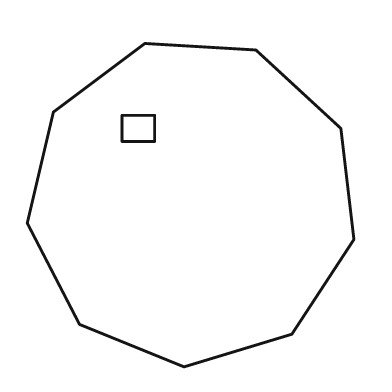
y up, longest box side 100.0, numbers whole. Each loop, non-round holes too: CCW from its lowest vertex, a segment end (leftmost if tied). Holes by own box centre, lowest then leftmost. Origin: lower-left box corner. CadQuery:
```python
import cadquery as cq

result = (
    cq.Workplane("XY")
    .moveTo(48.0, 0.0)
    .lineTo(81.0, 10.0)
    .lineTo(100.0, 39.0)
    .lineTo(96.0, 73.0)
    .lineTo(70.0, 97.0)
    .lineTo(36.0, 99.0)
    .lineTo(8.0, 78.0)
    .lineTo(0.0, 44.0)
    .lineTo(16.0, 13.0)
    .close()
    .moveTo(29.0, 69.0)
    .lineTo(39.0, 69.0)
    .lineTo(39.0, 77.0)
    .lineTo(29.0, 77.0)
    .close()
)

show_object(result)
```